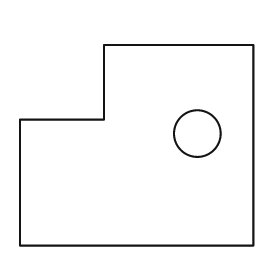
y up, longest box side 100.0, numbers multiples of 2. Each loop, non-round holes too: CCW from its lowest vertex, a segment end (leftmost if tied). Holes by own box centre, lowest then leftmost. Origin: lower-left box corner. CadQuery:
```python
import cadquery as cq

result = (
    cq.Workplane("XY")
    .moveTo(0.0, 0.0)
    .lineTo(100.0, 0.0)
    .lineTo(100.0, 86.0)
    .lineTo(36.0, 86.0)
    .lineTo(36.0, 54.0)
    .lineTo(0.0, 54.0)
    .close()
    .moveTo(76.0, 48.0)
    .circle(10.0)
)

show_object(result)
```